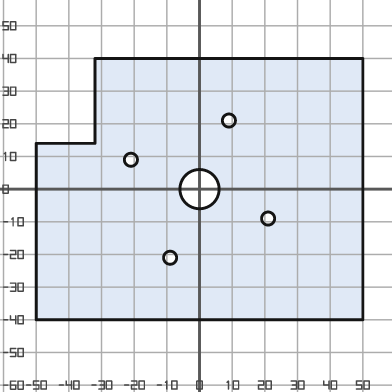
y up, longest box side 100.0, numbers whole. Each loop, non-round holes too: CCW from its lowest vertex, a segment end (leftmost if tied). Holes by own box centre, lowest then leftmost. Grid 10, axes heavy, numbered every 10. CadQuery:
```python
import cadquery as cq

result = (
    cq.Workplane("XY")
    .moveTo(-50.0, -40.0)
    .lineTo(50.0, -40.0)
    .lineTo(50.0, 40.0)
    .lineTo(-32.0, 40.0)
    .lineTo(-32.0, 14.0)
    .lineTo(-50.0, 14.0)
    .close()
    .moveTo(-9.0, -21.0)
    .circle(2.0)
    .moveTo(21.0, -9.0)
    .circle(2.0)
    .moveTo(0.0, 0.0)
    .circle(6.0)
    .moveTo(-21.0, 9.0)
    .circle(2.0)
    .moveTo(9.0, 21.0)
    .circle(2.0)
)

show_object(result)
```